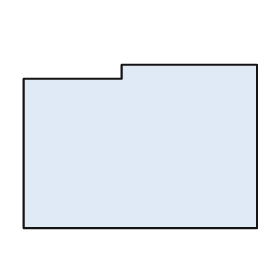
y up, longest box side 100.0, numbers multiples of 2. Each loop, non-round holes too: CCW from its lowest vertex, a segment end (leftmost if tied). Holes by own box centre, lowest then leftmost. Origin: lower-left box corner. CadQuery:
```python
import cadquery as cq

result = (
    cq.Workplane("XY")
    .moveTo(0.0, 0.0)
    .lineTo(100.0, 0.0)
    .lineTo(100.0, 70.0)
    .lineTo(42.0, 70.0)
    .lineTo(42.0, 64.0)
    .lineTo(0.0, 64.0)
    .close()
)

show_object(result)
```